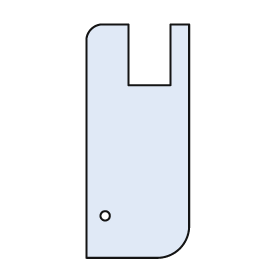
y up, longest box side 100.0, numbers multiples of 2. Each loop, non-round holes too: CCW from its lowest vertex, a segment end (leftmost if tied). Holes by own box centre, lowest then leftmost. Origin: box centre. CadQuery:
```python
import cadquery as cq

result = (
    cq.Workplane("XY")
    .moveTo(-22.0, -50.0)
    .lineTo(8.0, -50.0)
    .threePointArc((18.0, -46.0), (22.0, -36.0))
    .lineTo(22.0, 50.0)
    .lineTo(14.0, 50.0)
    .lineTo(14.0, 24.0)
    .lineTo(-4.0, 24.0)
    .lineTo(-4.0, 50.0)
    .lineTo(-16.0, 50.0)
    .threePointArc((-20.0, 48.0), (-22.0, 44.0))
    .close()
    .moveTo(-14.0, -32.0)
    .circle(2.0)
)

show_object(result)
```